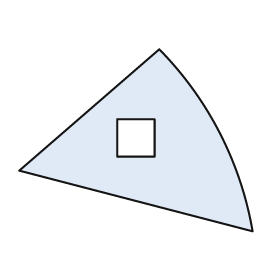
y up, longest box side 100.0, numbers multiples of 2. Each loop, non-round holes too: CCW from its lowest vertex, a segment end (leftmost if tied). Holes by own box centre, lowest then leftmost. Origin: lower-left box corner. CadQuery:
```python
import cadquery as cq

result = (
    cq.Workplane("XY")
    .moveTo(100.0, 0.0)
    .threePointArc((86.0, 42.0), (60.0, 78.0))
    .lineTo(0.0, 26.0)
    .close()
    .moveTo(42.0, 32.0)
    .lineTo(58.0, 32.0)
    .lineTo(58.0, 48.0)
    .lineTo(42.0, 48.0)
    .close()
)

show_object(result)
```